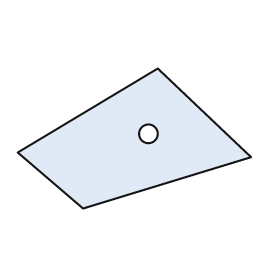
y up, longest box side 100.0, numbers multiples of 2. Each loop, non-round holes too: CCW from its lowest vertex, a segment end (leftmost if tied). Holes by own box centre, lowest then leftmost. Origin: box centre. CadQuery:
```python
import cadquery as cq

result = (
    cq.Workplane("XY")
    .moveTo(-22.0, -30.0)
    .lineTo(50.0, -8.0)
    .lineTo(10.0, 30.0)
    .lineTo(-50.0, -6.0)
    .close()
    .moveTo(6.0, 2.0)
    .circle(4.0)
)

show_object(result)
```